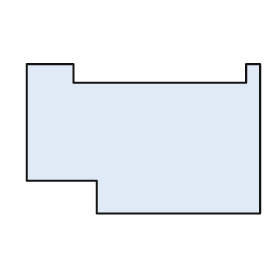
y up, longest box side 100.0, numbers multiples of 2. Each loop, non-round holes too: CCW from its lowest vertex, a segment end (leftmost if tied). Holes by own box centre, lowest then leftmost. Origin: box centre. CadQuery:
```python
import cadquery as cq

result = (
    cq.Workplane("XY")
    .moveTo(-20.0, -32.0)
    .lineTo(50.0, -32.0)
    .lineTo(50.0, 32.0)
    .lineTo(44.0, 32.0)
    .lineTo(44.0, 24.0)
    .lineTo(-30.0, 24.0)
    .lineTo(-30.0, 32.0)
    .lineTo(-50.0, 32.0)
    .lineTo(-50.0, -18.0)
    .lineTo(-20.0, -18.0)
    .close()
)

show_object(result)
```